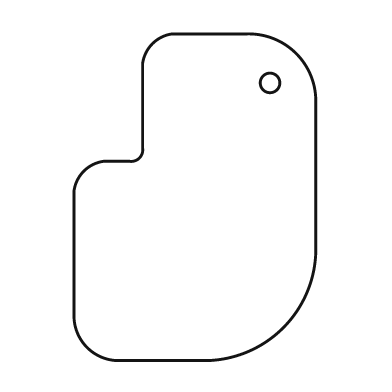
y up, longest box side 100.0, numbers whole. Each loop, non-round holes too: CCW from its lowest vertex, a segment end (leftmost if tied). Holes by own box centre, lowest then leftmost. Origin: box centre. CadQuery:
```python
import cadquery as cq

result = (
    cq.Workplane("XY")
    .moveTo(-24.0, -50.0)
    .lineTo(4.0, -50.0)
    .threePointArc((27.0, -40.0), (37.0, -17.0))
    .lineTo(37.0, 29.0)
    .threePointArc((31.0, 44.0), (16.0, 50.0))
    .lineTo(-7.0, 50.0)
    .threePointArc((-13.0, 47.0), (-16.0, 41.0))
    .lineTo(-16.0, 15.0)
    .threePointArc((-17.0, 12.0), (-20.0, 11.0))
    .lineTo(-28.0, 11.0)
    .threePointArc((-34.0, 8.0), (-37.0, 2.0))
    .lineTo(-37.0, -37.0)
    .threePointArc((-33.0, -46.0), (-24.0, -50.0))
    .close()
    .moveTo(23.0, 35.0)
    .circle(3.0)
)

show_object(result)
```